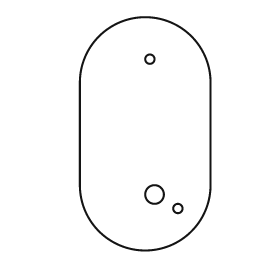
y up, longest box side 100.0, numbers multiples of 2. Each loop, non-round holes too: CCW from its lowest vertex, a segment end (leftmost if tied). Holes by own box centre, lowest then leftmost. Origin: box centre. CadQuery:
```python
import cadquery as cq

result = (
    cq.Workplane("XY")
    .moveTo(-28.0, -22.0)
    .threePointArc((0.0, -50.0), (28.0, -22.0))
    .lineTo(28.0, 22.0)
    .threePointArc((0.0, 50.0), (-28.0, 22.0))
    .close()
    .moveTo(14.0, -32.0)
    .circle(2.0)
    .moveTo(4.0, -26.0)
    .circle(4.0)
    .moveTo(2.0, 32.0)
    .circle(2.0)
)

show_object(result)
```